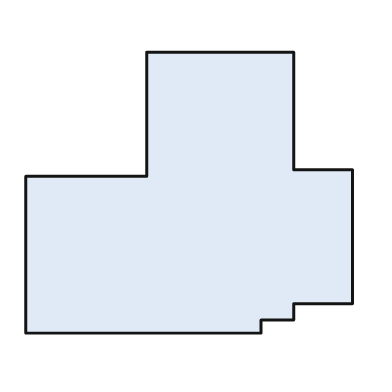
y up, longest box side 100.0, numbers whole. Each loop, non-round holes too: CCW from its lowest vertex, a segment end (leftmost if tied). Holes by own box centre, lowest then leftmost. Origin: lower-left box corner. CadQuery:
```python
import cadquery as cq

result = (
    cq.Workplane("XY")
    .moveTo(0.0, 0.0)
    .lineTo(72.0, 0.0)
    .lineTo(72.0, 4.0)
    .lineTo(82.0, 4.0)
    .lineTo(82.0, 9.0)
    .lineTo(100.0, 9.0)
    .lineTo(100.0, 50.0)
    .lineTo(82.0, 50.0)
    .lineTo(82.0, 86.0)
    .lineTo(37.0, 86.0)
    .lineTo(37.0, 48.0)
    .lineTo(0.0, 48.0)
    .close()
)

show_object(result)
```